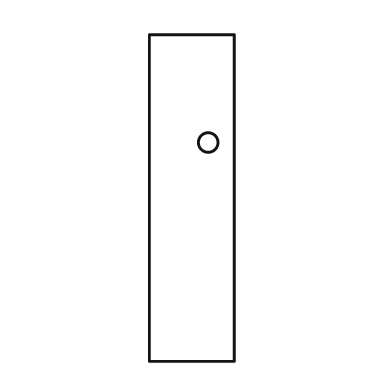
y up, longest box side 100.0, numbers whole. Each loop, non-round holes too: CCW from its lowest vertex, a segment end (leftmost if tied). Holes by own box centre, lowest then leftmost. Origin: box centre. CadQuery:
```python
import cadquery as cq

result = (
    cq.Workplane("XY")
    .moveTo(-13.0, -50.0)
    .lineTo(13.0, -50.0)
    .lineTo(13.0, 50.0)
    .lineTo(-13.0, 50.0)
    .close()
    .moveTo(5.0, 17.0)
    .circle(3.0)
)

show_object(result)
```